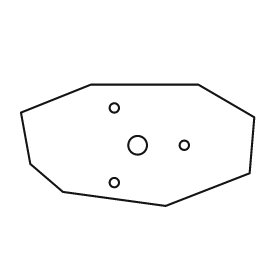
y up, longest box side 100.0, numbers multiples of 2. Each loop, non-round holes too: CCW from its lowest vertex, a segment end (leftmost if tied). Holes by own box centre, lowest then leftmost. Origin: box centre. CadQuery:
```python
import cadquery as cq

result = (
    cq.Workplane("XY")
    .moveTo(12.0, -26.0)
    .lineTo(48.0, -12.0)
    .lineTo(50.0, 12.0)
    .lineTo(26.0, 26.0)
    .lineTo(-20.0, 26.0)
    .lineTo(-50.0, 14.0)
    .lineTo(-46.0, -8.0)
    .lineTo(-32.0, -20.0)
    .close()
    .moveTo(-10.0, -16.0)
    .circle(2.0)
    .moveTo(0.0, 0.0)
    .circle(4.0)
    .moveTo(20.0, 0.0)
    .circle(2.0)
    .moveTo(-10.0, 16.0)
    .circle(2.0)
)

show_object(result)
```